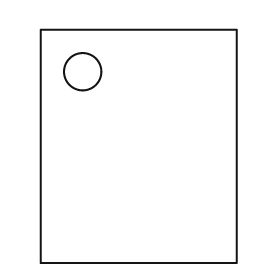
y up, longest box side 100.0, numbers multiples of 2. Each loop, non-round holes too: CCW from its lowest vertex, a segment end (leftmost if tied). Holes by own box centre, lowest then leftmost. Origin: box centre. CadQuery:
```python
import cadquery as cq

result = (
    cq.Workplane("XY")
    .moveTo(-42.0, -50.0)
    .lineTo(42.0, -50.0)
    .lineTo(42.0, 50.0)
    .lineTo(-42.0, 50.0)
    .close()
    .moveTo(-24.0, 32.0)
    .circle(8.0)
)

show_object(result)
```